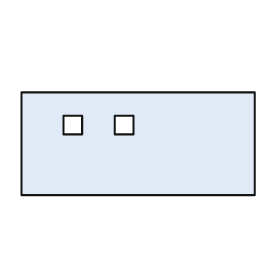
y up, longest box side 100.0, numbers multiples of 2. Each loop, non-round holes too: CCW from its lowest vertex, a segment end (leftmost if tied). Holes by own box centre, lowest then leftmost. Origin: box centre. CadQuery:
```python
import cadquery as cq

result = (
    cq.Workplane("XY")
    .moveTo(-50.0, -22.0)
    .lineTo(50.0, -22.0)
    .lineTo(50.0, 22.0)
    .lineTo(-50.0, 22.0)
    .close()
    .moveTo(-32.0, 4.0)
    .lineTo(-24.0, 4.0)
    .lineTo(-24.0, 12.0)
    .lineTo(-32.0, 12.0)
    .close()
    .moveTo(-10.0, 4.0)
    .lineTo(-2.0, 4.0)
    .lineTo(-2.0, 12.0)
    .lineTo(-10.0, 12.0)
    .close()
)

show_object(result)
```